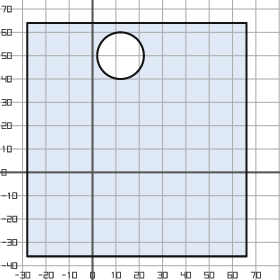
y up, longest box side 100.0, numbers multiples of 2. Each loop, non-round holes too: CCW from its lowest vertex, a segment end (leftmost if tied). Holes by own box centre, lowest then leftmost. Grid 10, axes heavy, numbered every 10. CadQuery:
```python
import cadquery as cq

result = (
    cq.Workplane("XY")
    .moveTo(-28.0, -36.0)
    .lineTo(66.0, -36.0)
    .lineTo(66.0, 64.0)
    .lineTo(-28.0, 64.0)
    .close()
    .moveTo(12.0, 50.0)
    .circle(10.0)
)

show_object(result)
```